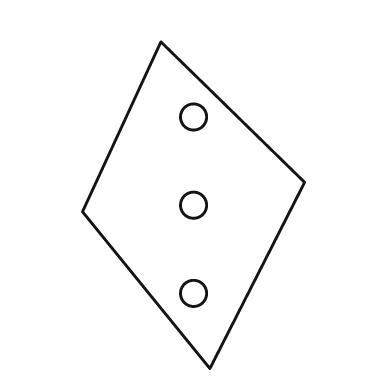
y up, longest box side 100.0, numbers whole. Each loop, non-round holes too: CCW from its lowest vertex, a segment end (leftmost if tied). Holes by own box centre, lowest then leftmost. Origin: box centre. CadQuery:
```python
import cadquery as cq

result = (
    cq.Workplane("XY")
    .moveTo(5.0, -50.0)
    .lineTo(34.0, 7.0)
    .lineTo(-10.0, 50.0)
    .lineTo(-34.0, -2.0)
    .close()
    .moveTo(0.0, -27.0)
    .circle(4.0)
    .moveTo(0.0, 0.0)
    .circle(4.0)
    .moveTo(0.0, 27.0)
    .circle(4.0)
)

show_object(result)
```